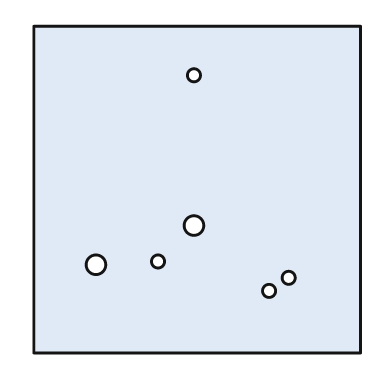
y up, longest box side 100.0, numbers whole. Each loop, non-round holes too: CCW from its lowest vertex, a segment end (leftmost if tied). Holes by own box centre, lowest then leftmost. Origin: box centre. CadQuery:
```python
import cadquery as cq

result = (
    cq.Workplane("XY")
    .moveTo(-50.0, -50.0)
    .lineTo(50.0, -50.0)
    .lineTo(50.0, 50.0)
    .lineTo(-50.0, 50.0)
    .close()
    .moveTo(22.0, -31.0)
    .circle(2.0)
    .moveTo(28.0, -27.0)
    .circle(2.0)
    .moveTo(-31.0, -23.0)
    .circle(3.0)
    .moveTo(-12.0, -22.0)
    .circle(2.0)
    .moveTo(-1.0, -11.0)
    .circle(3.0)
    .moveTo(-1.0, 35.0)
    .circle(2.0)
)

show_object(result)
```